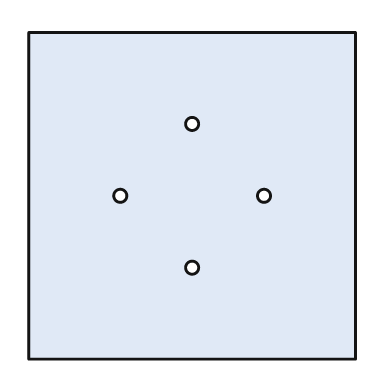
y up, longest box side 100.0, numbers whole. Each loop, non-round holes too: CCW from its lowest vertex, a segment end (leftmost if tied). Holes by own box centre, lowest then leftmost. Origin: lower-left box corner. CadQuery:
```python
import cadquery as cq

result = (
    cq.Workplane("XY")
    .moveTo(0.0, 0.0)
    .lineTo(100.0, 0.0)
    .lineTo(100.0, 100.0)
    .lineTo(0.0, 100.0)
    .close()
    .moveTo(50.0, 28.0)
    .circle(2.0)
    .moveTo(28.0, 50.0)
    .circle(2.0)
    .moveTo(72.0, 50.0)
    .circle(2.0)
    .moveTo(50.0, 72.0)
    .circle(2.0)
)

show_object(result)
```